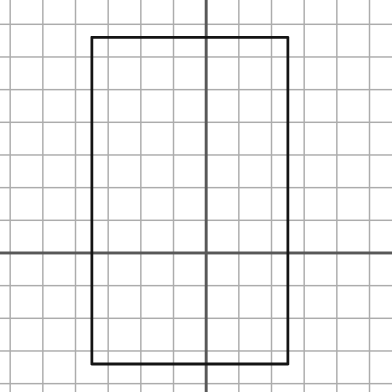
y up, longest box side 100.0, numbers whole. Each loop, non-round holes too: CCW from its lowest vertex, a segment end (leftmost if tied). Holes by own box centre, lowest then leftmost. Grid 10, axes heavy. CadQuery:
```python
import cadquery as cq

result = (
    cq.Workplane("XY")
    .moveTo(-35.0, -34.0)
    .lineTo(25.0, -34.0)
    .lineTo(25.0, 66.0)
    .lineTo(-35.0, 66.0)
    .close()
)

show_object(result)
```